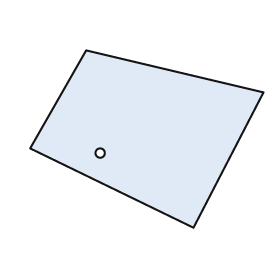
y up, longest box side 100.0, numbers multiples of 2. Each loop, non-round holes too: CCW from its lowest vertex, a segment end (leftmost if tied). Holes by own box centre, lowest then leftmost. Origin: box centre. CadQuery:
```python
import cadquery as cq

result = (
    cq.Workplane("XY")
    .moveTo(20.0, -38.0)
    .lineTo(50.0, 20.0)
    .lineTo(-26.0, 38.0)
    .lineTo(-50.0, -4.0)
    .close()
    .moveTo(-20.0, -6.0)
    .circle(2.0)
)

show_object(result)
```